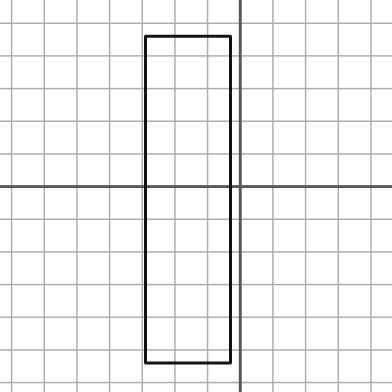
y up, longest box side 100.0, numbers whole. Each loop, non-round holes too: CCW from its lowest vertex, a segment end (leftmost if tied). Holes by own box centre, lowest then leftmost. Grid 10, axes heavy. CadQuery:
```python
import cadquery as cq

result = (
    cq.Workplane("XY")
    .moveTo(-29.0, -54.0)
    .lineTo(-3.0, -54.0)
    .lineTo(-3.0, 46.0)
    .lineTo(-29.0, 46.0)
    .close()
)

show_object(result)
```